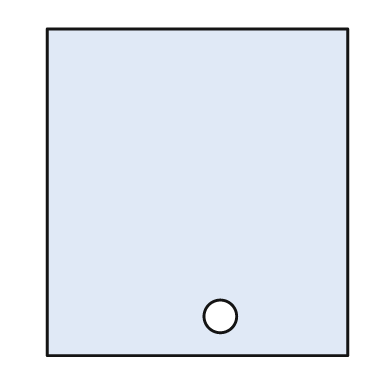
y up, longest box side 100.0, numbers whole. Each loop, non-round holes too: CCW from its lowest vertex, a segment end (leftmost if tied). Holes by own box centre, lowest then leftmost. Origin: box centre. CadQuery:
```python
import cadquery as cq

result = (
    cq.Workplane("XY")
    .moveTo(-46.0, -50.0)
    .lineTo(46.0, -50.0)
    .lineTo(46.0, 50.0)
    .lineTo(-46.0, 50.0)
    .close()
    .moveTo(7.0, -38.0)
    .circle(5.0)
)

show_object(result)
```